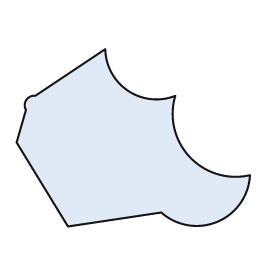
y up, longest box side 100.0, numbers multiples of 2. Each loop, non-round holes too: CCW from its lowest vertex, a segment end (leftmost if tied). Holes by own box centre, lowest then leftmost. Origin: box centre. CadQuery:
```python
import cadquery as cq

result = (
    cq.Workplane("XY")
    .moveTo(-28.0, -38.0)
    .lineTo(12.0, -32.0)
    .threePointArc((36.0, -36.0), (50.0, -16.0))
    .threePointArc((24.0, -8.0), (18.0, 18.0))
    .threePointArc((-2.0, 20.0), (-12.0, 38.0))
    .lineTo(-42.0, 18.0)
    .threePointArc((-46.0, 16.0), (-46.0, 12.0))
    .lineTo(-50.0, -2.0)
    .close()
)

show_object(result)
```